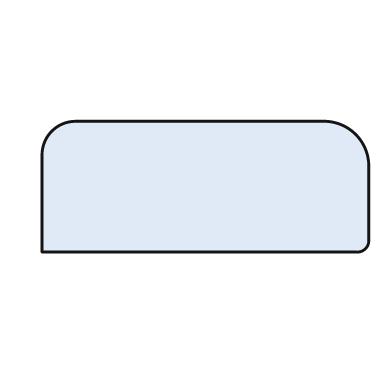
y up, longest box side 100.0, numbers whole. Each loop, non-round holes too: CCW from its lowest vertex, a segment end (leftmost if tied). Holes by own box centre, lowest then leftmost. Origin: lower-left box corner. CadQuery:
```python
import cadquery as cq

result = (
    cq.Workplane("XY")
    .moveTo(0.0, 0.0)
    .lineTo(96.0, 0.0)
    .threePointArc((99.0, 1.0), (100.0, 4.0))
    .lineTo(100.0, 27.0)
    .threePointArc((96.0, 36.0), (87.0, 40.0))
    .lineTo(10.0, 40.0)
    .threePointArc((3.0, 37.0), (0.0, 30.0))
    .close()
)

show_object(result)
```